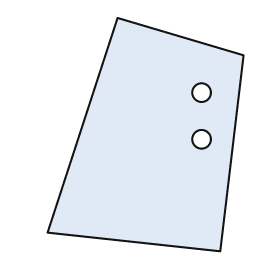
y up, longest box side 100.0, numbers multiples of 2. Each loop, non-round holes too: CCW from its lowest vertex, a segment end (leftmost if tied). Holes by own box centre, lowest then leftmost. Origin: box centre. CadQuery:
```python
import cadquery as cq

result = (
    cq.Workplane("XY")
    .moveTo(32.0, -50.0)
    .lineTo(42.0, 34.0)
    .lineTo(-12.0, 50.0)
    .lineTo(-42.0, -42.0)
    .close()
    .moveTo(24.0, -2.0)
    .circle(4.0)
    .moveTo(24.0, 18.0)
    .circle(4.0)
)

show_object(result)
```